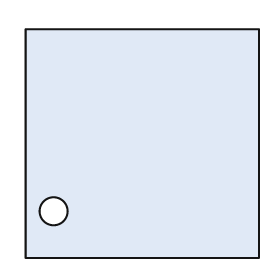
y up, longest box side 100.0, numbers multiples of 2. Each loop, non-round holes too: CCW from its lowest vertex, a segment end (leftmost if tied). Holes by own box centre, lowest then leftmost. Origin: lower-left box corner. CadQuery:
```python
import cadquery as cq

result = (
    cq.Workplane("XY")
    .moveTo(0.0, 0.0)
    .lineTo(100.0, 0.0)
    .lineTo(100.0, 98.0)
    .lineTo(0.0, 98.0)
    .close()
    .moveTo(12.0, 20.0)
    .circle(6.0)
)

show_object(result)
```